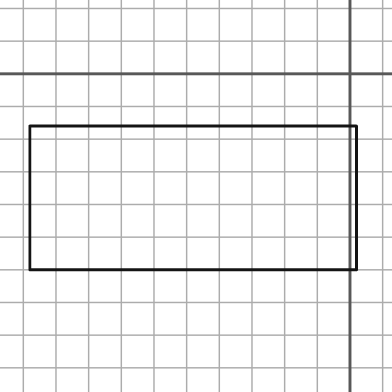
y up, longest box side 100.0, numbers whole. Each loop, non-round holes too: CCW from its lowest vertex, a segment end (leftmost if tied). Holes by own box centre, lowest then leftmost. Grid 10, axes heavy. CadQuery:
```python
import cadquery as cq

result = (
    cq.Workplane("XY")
    .moveTo(-98.0, -60.0)
    .lineTo(2.0, -60.0)
    .lineTo(2.0, -16.0)
    .lineTo(-98.0, -16.0)
    .close()
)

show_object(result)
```